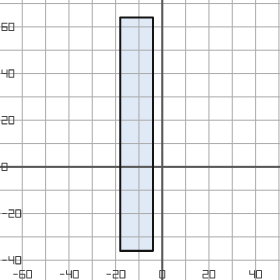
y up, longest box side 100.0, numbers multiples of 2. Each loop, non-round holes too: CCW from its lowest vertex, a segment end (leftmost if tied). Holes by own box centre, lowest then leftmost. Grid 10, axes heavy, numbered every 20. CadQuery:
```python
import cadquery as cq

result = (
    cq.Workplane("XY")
    .moveTo(-18.0, -36.0)
    .lineTo(-4.0, -36.0)
    .lineTo(-4.0, 64.0)
    .lineTo(-18.0, 64.0)
    .close()
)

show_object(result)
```